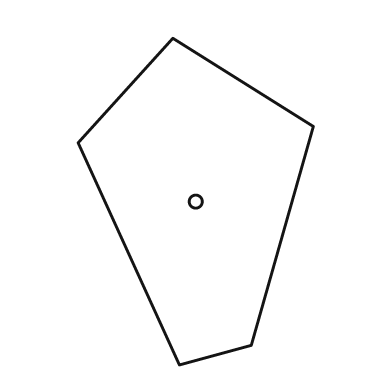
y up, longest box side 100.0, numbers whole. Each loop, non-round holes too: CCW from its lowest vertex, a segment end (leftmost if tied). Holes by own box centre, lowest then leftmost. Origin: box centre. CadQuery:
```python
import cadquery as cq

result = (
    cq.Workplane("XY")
    .moveTo(-5.0, -50.0)
    .lineTo(17.0, -44.0)
    .lineTo(36.0, 23.0)
    .lineTo(-7.0, 50.0)
    .lineTo(-36.0, 18.0)
    .close()
    .moveTo(0.0, 0.0)
    .circle(2.0)
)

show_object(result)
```